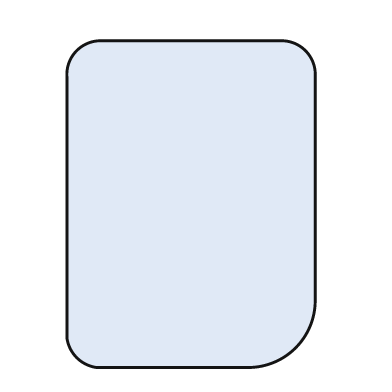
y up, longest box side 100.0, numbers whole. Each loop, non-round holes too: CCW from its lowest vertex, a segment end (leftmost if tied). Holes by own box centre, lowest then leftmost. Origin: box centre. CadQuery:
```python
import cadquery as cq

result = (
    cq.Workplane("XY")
    .moveTo(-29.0, -50.0)
    .lineTo(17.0, -50.0)
    .threePointArc((32.0, -44.0), (38.0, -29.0))
    .lineTo(38.0, 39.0)
    .threePointArc((35.0, 47.0), (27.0, 50.0))
    .lineTo(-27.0, 50.0)
    .threePointArc((-35.0, 47.0), (-38.0, 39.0))
    .lineTo(-38.0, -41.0)
    .threePointArc((-35.0, -47.0), (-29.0, -50.0))
    .close()
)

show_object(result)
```